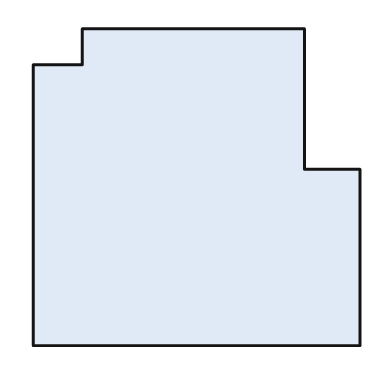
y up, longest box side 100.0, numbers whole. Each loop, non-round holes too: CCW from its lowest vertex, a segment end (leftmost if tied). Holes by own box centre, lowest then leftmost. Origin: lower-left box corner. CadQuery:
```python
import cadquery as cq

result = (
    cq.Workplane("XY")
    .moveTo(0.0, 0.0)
    .lineTo(100.0, 0.0)
    .lineTo(100.0, 54.0)
    .lineTo(83.0, 54.0)
    .lineTo(83.0, 97.0)
    .lineTo(15.0, 97.0)
    .lineTo(15.0, 86.0)
    .lineTo(0.0, 86.0)
    .close()
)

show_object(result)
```